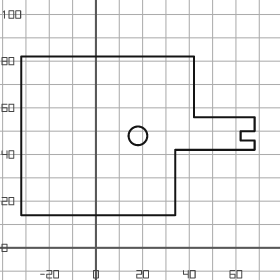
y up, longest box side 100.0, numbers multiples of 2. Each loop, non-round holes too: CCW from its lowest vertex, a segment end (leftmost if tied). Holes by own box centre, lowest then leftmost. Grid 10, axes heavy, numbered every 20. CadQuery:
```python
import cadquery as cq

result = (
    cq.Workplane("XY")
    .moveTo(-32.0, 14.0)
    .lineTo(34.0, 14.0)
    .lineTo(34.0, 42.0)
    .lineTo(68.0, 42.0)
    .lineTo(68.0, 46.0)
    .lineTo(62.0, 46.0)
    .lineTo(62.0, 50.0)
    .lineTo(68.0, 50.0)
    .lineTo(68.0, 56.0)
    .lineTo(42.0, 56.0)
    .lineTo(42.0, 82.0)
    .lineTo(-32.0, 82.0)
    .close()
    .moveTo(18.0, 48.0)
    .circle(4.0)
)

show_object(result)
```